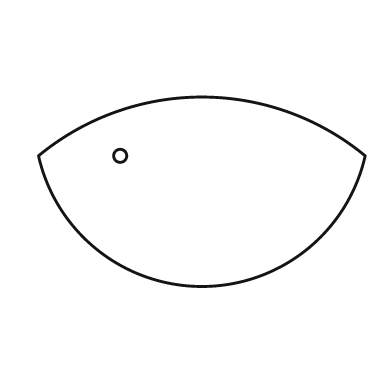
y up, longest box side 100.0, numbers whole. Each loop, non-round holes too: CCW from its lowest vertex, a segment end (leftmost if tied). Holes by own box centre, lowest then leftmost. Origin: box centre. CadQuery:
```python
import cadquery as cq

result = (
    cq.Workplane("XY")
    .moveTo(-50.0, 11.0)
    .threePointArc((0.0, -29.0), (50.0, 11.0))
    .threePointArc((0.0, 29.0), (-50.0, 11.0))
    .close()
    .moveTo(-25.0, 11.0)
    .circle(2.0)
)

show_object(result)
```